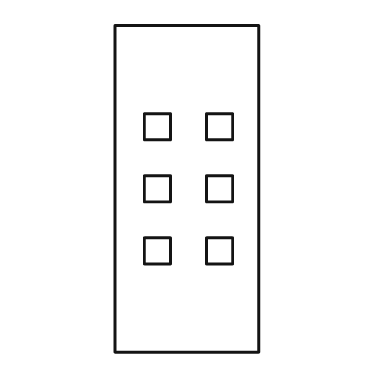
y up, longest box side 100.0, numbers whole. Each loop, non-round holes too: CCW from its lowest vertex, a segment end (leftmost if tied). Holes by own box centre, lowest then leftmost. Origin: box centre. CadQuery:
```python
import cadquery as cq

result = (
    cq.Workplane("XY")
    .moveTo(-22.0, -50.0)
    .lineTo(22.0, -50.0)
    .lineTo(22.0, 50.0)
    .lineTo(-22.0, 50.0)
    .close()
    .moveTo(-13.0, -23.0)
    .lineTo(-5.0, -23.0)
    .lineTo(-5.0, -15.0)
    .lineTo(-13.0, -15.0)
    .close()
    .moveTo(6.0, -23.0)
    .lineTo(14.0, -23.0)
    .lineTo(14.0, -15.0)
    .lineTo(6.0, -15.0)
    .close()
    .moveTo(-13.0, -4.0)
    .lineTo(-5.0, -4.0)
    .lineTo(-5.0, 4.0)
    .lineTo(-13.0, 4.0)
    .close()
    .moveTo(6.0, -4.0)
    .lineTo(14.0, -4.0)
    .lineTo(14.0, 4.0)
    .lineTo(6.0, 4.0)
    .close()
    .moveTo(-13.0, 15.0)
    .lineTo(-5.0, 15.0)
    .lineTo(-5.0, 23.0)
    .lineTo(-13.0, 23.0)
    .close()
    .moveTo(6.0, 15.0)
    .lineTo(14.0, 15.0)
    .lineTo(14.0, 23.0)
    .lineTo(6.0, 23.0)
    .close()
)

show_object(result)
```